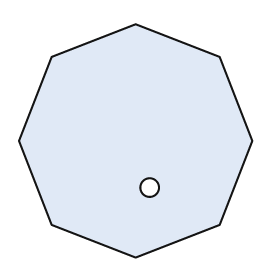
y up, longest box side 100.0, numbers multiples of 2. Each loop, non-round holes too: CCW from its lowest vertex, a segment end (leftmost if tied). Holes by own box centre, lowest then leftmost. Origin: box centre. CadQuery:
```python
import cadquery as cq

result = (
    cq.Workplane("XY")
    .moveTo(0.0, -50.0)
    .lineTo(36.0, -36.0)
    .lineTo(50.0, 0.0)
    .lineTo(36.0, 36.0)
    .lineTo(0.0, 50.0)
    .lineTo(-36.0, 36.0)
    .lineTo(-50.0, 0.0)
    .lineTo(-36.0, -36.0)
    .close()
    .moveTo(6.0, -20.0)
    .circle(4.0)
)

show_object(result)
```